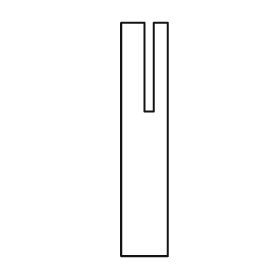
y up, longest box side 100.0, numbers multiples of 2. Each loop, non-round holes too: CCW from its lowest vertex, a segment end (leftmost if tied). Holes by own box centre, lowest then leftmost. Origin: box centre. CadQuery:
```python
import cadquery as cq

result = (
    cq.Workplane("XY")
    .moveTo(-10.0, -50.0)
    .lineTo(10.0, -50.0)
    .lineTo(10.0, 50.0)
    .lineTo(4.0, 50.0)
    .lineTo(4.0, 12.0)
    .lineTo(0.0, 12.0)
    .lineTo(0.0, 50.0)
    .lineTo(-10.0, 50.0)
    .close()
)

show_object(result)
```